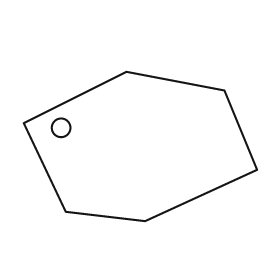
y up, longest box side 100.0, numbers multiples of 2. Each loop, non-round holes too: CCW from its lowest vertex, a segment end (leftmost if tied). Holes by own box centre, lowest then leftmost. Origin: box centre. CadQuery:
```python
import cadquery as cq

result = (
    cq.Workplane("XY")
    .moveTo(2.0, -32.0)
    .lineTo(50.0, -10.0)
    .lineTo(36.0, 24.0)
    .lineTo(-6.0, 32.0)
    .lineTo(-50.0, 10.0)
    .lineTo(-32.0, -28.0)
    .close()
    .moveTo(-34.0, 8.0)
    .circle(4.0)
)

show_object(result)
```